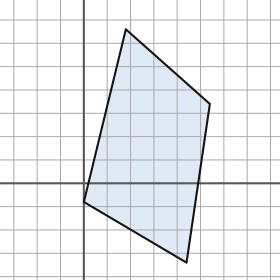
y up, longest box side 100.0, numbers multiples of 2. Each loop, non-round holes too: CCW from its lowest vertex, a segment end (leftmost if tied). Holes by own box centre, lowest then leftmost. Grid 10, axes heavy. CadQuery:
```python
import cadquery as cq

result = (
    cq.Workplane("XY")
    .moveTo(44.0, -34.0)
    .lineTo(54.0, 34.0)
    .lineTo(18.0, 66.0)
    .lineTo(0.0, -8.0)
    .close()
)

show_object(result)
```